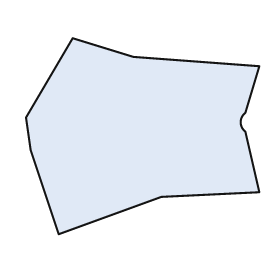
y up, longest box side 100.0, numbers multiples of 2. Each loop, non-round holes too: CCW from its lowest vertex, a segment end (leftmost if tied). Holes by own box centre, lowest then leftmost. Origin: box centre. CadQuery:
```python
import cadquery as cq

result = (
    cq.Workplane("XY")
    .moveTo(-36.0, -42.0)
    .lineTo(8.0, -26.0)
    .lineTo(50.0, -24.0)
    .lineTo(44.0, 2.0)
    .threePointArc((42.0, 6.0), (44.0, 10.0))
    .lineTo(50.0, 30.0)
    .lineTo(-4.0, 34.0)
    .lineTo(-30.0, 42.0)
    .lineTo(-50.0, 8.0)
    .lineTo(-48.0, -6.0)
    .close()
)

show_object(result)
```